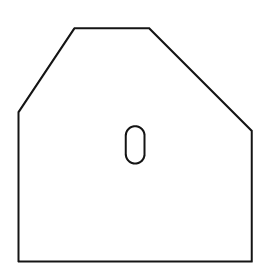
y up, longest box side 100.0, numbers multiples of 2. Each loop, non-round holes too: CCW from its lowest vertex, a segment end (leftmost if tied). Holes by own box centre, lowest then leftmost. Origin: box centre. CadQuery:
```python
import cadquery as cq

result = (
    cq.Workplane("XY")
    .moveTo(-50.0, -50.0)
    .lineTo(50.0, -50.0)
    .lineTo(50.0, 6.0)
    .lineTo(6.0, 50.0)
    .lineTo(-26.0, 50.0)
    .lineTo(-50.0, 14.0)
    .close()
    .moveTo(-4.0, -4.0)
    .threePointArc((0.0, -8.0), (4.0, -4.0))
    .lineTo(4.0, 4.0)
    .threePointArc((0.0, 8.0), (-4.0, 4.0))
    .close()
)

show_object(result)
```